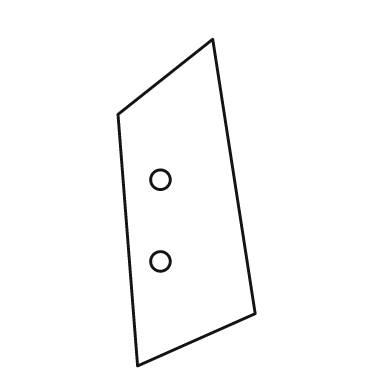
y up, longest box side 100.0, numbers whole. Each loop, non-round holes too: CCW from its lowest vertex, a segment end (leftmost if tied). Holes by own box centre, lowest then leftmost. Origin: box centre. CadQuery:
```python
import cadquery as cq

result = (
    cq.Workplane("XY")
    .moveTo(-15.0, -50.0)
    .lineTo(21.0, -34.0)
    .lineTo(8.0, 50.0)
    .lineTo(-21.0, 27.0)
    .close()
    .moveTo(-8.0, -18.0)
    .circle(3.0)
    .moveTo(-8.0, 7.0)
    .circle(3.0)
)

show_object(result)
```